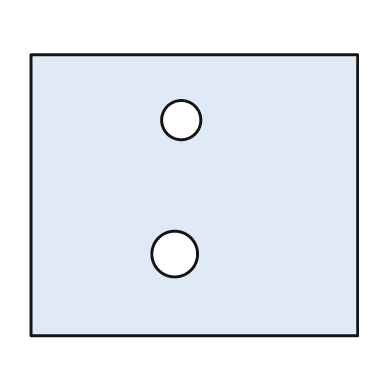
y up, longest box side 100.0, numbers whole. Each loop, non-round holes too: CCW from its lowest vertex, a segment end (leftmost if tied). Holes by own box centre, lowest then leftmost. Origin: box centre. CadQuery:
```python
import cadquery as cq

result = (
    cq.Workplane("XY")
    .moveTo(-50.0, -43.0)
    .lineTo(50.0, -43.0)
    .lineTo(50.0, 43.0)
    .lineTo(-50.0, 43.0)
    .close()
    .moveTo(-6.0, -18.0)
    .circle(7.0)
    .moveTo(-4.0, 23.0)
    .circle(6.0)
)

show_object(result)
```